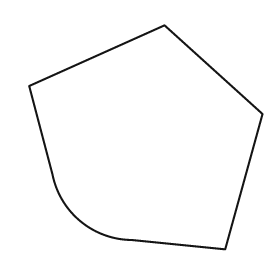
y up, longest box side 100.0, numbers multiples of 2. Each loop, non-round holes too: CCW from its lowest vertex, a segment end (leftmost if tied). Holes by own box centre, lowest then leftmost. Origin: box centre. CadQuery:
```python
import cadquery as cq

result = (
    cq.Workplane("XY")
    .moveTo(34.0, -48.0)
    .lineTo(50.0, 10.0)
    .lineTo(8.0, 48.0)
    .lineTo(-50.0, 22.0)
    .lineTo(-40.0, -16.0)
    .threePointArc((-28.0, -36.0), (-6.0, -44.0))
    .close()
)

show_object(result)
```